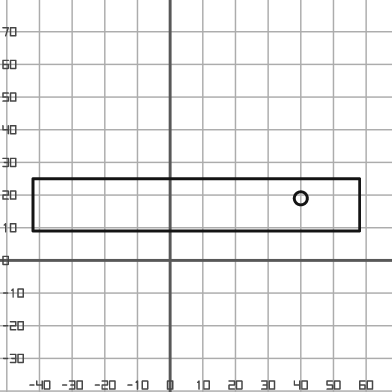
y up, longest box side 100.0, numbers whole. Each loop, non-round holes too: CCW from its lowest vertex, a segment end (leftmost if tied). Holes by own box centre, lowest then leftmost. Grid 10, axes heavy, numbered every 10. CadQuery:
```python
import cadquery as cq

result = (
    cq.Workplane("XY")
    .moveTo(-42.0, 9.0)
    .lineTo(58.0, 9.0)
    .lineTo(58.0, 25.0)
    .lineTo(-42.0, 25.0)
    .close()
    .moveTo(40.0, 19.0)
    .circle(2.0)
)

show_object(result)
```